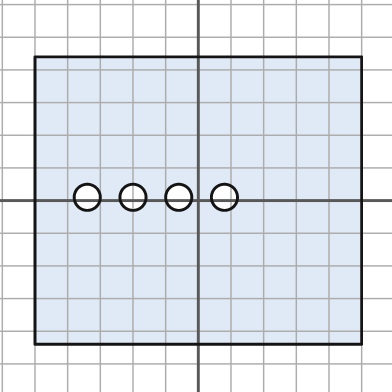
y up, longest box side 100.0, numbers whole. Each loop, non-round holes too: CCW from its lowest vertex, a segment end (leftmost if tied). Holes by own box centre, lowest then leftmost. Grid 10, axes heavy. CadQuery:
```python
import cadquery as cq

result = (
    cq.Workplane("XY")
    .moveTo(-50.0, -44.0)
    .lineTo(50.0, -44.0)
    .lineTo(50.0, 44.0)
    .lineTo(-50.0, 44.0)
    .close()
    .moveTo(-34.0, 1.0)
    .circle(4.0)
    .moveTo(-20.0, 1.0)
    .circle(4.0)
    .moveTo(-6.0, 1.0)
    .circle(4.0)
    .moveTo(8.0, 1.0)
    .circle(4.0)
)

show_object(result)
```